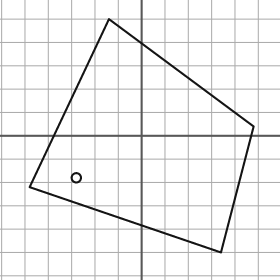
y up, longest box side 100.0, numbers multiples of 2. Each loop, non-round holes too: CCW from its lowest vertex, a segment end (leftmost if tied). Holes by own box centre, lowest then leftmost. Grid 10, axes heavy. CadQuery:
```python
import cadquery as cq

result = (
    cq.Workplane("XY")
    .moveTo(34.0, -50.0)
    .lineTo(48.0, 4.0)
    .lineTo(-14.0, 50.0)
    .lineTo(-48.0, -22.0)
    .close()
    .moveTo(-28.0, -18.0)
    .circle(2.0)
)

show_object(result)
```